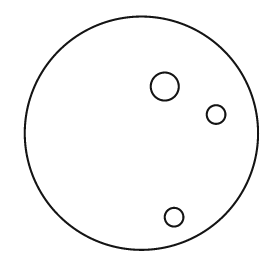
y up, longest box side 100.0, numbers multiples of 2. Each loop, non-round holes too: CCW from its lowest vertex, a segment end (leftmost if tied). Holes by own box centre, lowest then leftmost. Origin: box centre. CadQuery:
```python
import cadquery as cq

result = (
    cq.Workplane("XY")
    .moveTo(0.0, 0.0)
    .circle(50.0)
    .moveTo(14.0, -36.0)
    .circle(4.0)
    .moveTo(32.0, 8.0)
    .circle(4.0)
    .moveTo(10.0, 20.0)
    .circle(6.0)
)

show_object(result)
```